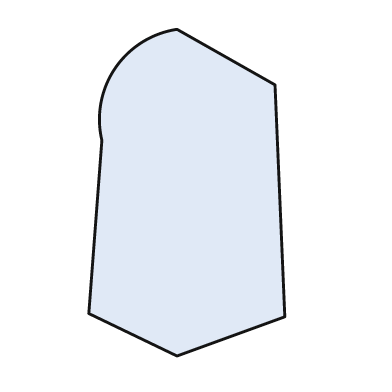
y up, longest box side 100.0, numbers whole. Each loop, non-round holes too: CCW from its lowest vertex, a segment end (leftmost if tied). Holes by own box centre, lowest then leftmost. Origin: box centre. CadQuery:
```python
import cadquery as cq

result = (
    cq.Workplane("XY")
    .moveTo(-3.0, -50.0)
    .lineTo(30.0, -38.0)
    .lineTo(27.0, 33.0)
    .lineTo(-3.0, 50.0)
    .threePointArc((-22.0, 38.0), (-26.0, 16.0))
    .lineTo(-30.0, -37.0)
    .close()
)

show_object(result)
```